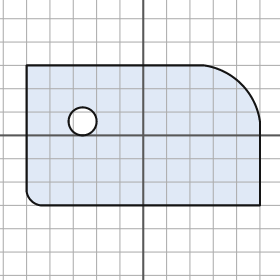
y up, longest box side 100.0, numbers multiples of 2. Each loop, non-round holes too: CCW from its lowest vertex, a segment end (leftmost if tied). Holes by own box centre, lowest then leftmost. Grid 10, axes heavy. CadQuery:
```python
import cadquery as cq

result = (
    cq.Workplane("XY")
    .moveTo(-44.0, -30.0)
    .lineTo(50.0, -30.0)
    .lineTo(50.0, 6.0)
    .threePointArc((42.0, 22.0), (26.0, 30.0))
    .lineTo(-50.0, 30.0)
    .lineTo(-50.0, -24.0)
    .threePointArc((-48.0, -28.0), (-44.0, -30.0))
    .close()
    .moveTo(-26.0, 6.0)
    .circle(6.0)
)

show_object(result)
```